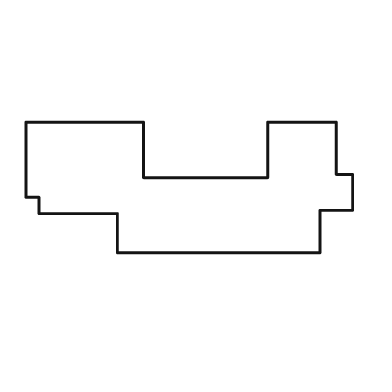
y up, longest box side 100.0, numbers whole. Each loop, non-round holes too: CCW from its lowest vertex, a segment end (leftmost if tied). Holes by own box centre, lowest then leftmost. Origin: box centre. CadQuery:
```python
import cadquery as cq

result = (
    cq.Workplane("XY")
    .moveTo(-22.0, -20.0)
    .lineTo(40.0, -20.0)
    .lineTo(40.0, -7.0)
    .lineTo(50.0, -7.0)
    .lineTo(50.0, 4.0)
    .lineTo(45.0, 4.0)
    .lineTo(45.0, 20.0)
    .lineTo(24.0, 20.0)
    .lineTo(24.0, 3.0)
    .lineTo(-14.0, 3.0)
    .lineTo(-14.0, 20.0)
    .lineTo(-50.0, 20.0)
    .lineTo(-50.0, -3.0)
    .lineTo(-46.0, -3.0)
    .lineTo(-46.0, -8.0)
    .lineTo(-22.0, -8.0)
    .close()
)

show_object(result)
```